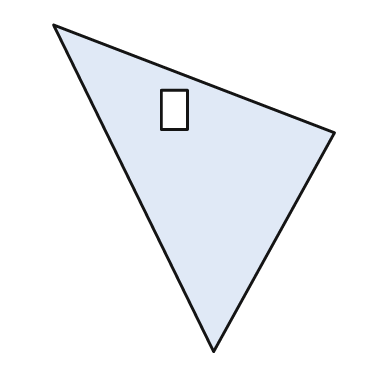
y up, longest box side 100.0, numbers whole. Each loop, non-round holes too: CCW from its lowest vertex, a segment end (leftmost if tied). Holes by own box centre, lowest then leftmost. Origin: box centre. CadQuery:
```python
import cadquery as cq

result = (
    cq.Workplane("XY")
    .moveTo(6.0, -50.0)
    .lineTo(43.0, 17.0)
    .lineTo(-43.0, 50.0)
    .close()
    .moveTo(-10.0, 18.0)
    .lineTo(-2.0, 18.0)
    .lineTo(-2.0, 30.0)
    .lineTo(-10.0, 30.0)
    .close()
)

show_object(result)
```